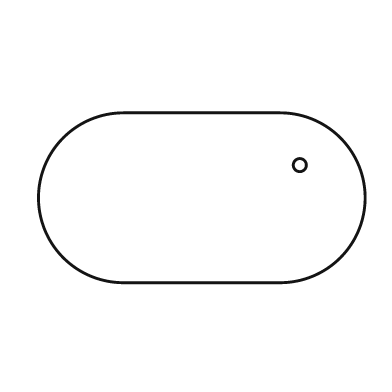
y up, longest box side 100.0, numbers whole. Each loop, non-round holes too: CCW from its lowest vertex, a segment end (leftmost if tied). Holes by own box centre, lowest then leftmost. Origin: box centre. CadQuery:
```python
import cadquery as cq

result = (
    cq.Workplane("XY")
    .moveTo(-24.0, -26.0)
    .lineTo(24.0, -26.0)
    .threePointArc((50.0, 0.0), (24.0, 26.0))
    .lineTo(-24.0, 26.0)
    .threePointArc((-50.0, 0.0), (-24.0, -26.0))
    .close()
    .moveTo(30.0, 10.0)
    .circle(2.0)
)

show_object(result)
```